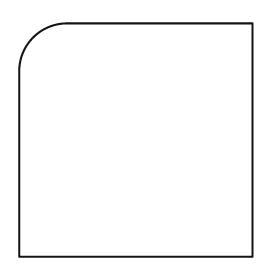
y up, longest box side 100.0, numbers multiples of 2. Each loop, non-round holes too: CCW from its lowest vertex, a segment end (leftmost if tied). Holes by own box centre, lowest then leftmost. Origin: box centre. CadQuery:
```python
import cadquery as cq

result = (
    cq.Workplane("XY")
    .moveTo(-50.0, -50.0)
    .lineTo(50.0, -50.0)
    .lineTo(50.0, 50.0)
    .lineTo(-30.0, 50.0)
    .threePointArc((-44.0, 44.0), (-50.0, 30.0))
    .close()
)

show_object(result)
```